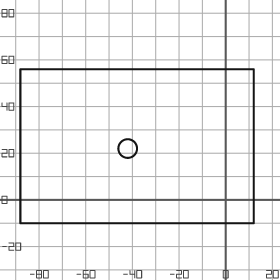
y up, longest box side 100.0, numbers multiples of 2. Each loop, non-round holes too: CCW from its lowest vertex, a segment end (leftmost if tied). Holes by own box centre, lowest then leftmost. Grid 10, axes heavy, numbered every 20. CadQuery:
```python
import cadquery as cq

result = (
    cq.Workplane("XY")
    .moveTo(-88.0, -10.0)
    .lineTo(12.0, -10.0)
    .lineTo(12.0, 56.0)
    .lineTo(-88.0, 56.0)
    .close()
    .moveTo(-42.0, 22.0)
    .circle(4.0)
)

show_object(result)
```